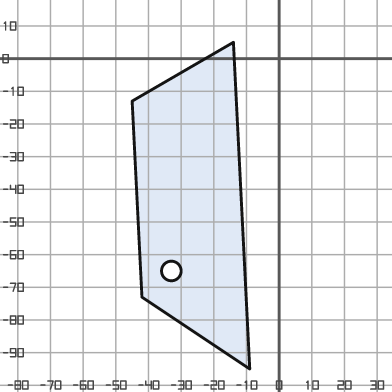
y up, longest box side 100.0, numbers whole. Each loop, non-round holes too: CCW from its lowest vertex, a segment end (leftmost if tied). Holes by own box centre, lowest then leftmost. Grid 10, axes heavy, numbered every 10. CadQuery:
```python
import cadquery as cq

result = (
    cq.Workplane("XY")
    .moveTo(-9.0, -95.0)
    .lineTo(-14.0, 5.0)
    .lineTo(-45.0, -13.0)
    .lineTo(-42.0, -73.0)
    .close()
    .moveTo(-33.0, -65.0)
    .circle(3.0)
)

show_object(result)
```